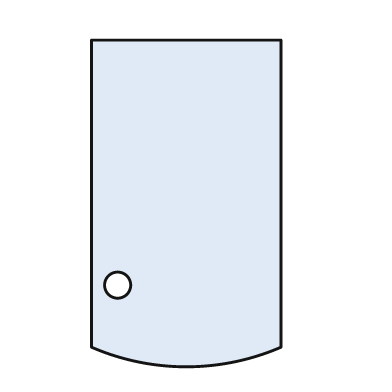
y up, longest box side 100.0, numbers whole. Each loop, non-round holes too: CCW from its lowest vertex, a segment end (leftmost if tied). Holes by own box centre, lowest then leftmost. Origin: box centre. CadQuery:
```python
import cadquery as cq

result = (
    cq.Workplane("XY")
    .moveTo(-29.0, -44.0)
    .threePointArc((0.0, -50.0), (29.0, -44.0))
    .lineTo(29.0, 50.0)
    .lineTo(-29.0, 50.0)
    .close()
    .moveTo(-21.0, -25.0)
    .circle(4.0)
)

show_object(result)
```